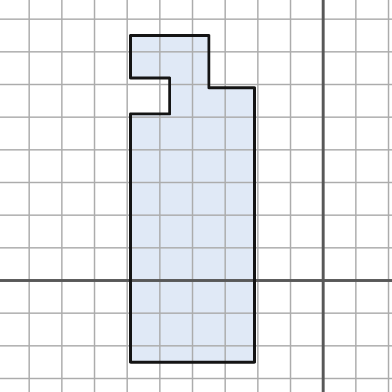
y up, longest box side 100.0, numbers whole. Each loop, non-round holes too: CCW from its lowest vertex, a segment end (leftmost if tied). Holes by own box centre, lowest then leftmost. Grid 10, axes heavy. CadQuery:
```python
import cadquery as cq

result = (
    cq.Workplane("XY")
    .moveTo(-59.0, -25.0)
    .lineTo(-21.0, -25.0)
    .lineTo(-21.0, 59.0)
    .lineTo(-35.0, 59.0)
    .lineTo(-35.0, 75.0)
    .lineTo(-59.0, 75.0)
    .lineTo(-59.0, 62.0)
    .lineTo(-47.0, 62.0)
    .lineTo(-47.0, 51.0)
    .lineTo(-59.0, 51.0)
    .close()
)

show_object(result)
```